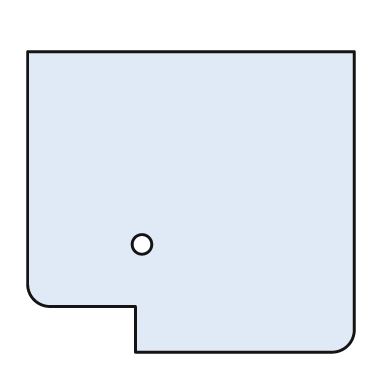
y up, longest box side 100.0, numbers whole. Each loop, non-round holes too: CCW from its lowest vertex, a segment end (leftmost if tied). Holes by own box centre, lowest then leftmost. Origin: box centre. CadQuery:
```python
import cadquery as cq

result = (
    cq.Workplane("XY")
    .moveTo(-17.0, -46.0)
    .lineTo(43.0, -46.0)
    .threePointArc((48.0, -44.0), (50.0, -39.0))
    .lineTo(50.0, 46.0)
    .lineTo(-50.0, 46.0)
    .lineTo(-50.0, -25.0)
    .threePointArc((-48.0, -30.0), (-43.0, -32.0))
    .lineTo(-17.0, -32.0)
    .close()
    .moveTo(-15.0, -13.0)
    .circle(3.0)
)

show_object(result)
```